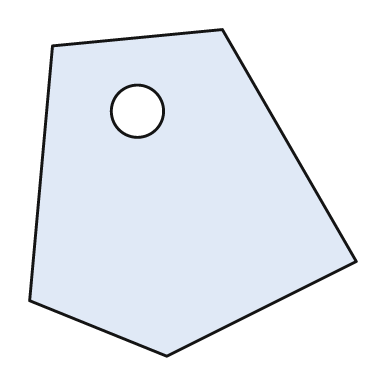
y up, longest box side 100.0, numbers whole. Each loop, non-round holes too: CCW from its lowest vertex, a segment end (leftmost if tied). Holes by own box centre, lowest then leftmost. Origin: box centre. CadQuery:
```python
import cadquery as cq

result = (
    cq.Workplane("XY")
    .moveTo(-8.0, -50.0)
    .lineTo(50.0, -21.0)
    .lineTo(9.0, 50.0)
    .lineTo(-43.0, 45.0)
    .lineTo(-50.0, -33.0)
    .close()
    .moveTo(-17.0, 25.0)
    .circle(8.0)
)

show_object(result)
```